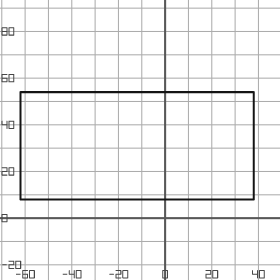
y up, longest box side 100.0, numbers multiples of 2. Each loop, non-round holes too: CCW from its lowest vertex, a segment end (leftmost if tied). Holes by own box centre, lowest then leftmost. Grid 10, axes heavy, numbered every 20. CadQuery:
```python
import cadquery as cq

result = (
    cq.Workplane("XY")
    .moveTo(-62.0, 8.0)
    .lineTo(38.0, 8.0)
    .lineTo(38.0, 54.0)
    .lineTo(-62.0, 54.0)
    .close()
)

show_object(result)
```